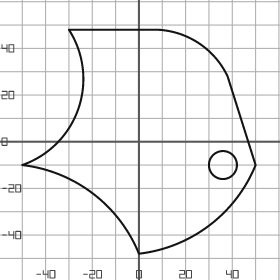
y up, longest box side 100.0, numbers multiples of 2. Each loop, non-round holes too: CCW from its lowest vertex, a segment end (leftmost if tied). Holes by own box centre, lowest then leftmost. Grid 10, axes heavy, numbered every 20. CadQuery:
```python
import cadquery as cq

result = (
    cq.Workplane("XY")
    .moveTo(0.0, -48.0)
    .threePointArc((30.0, -36.0), (50.0, -10.0))
    .lineTo(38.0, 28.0)
    .threePointArc((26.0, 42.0), (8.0, 48.0))
    .lineTo(-30.0, 48.0)
    .threePointArc((-26.0, 14.0), (-50.0, -10.0))
    .threePointArc((-20.0, -22.0), (0.0, -48.0))
    .close()
    .moveTo(36.0, -10.0)
    .circle(6.0)
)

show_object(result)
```